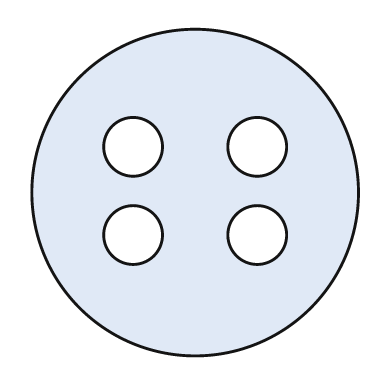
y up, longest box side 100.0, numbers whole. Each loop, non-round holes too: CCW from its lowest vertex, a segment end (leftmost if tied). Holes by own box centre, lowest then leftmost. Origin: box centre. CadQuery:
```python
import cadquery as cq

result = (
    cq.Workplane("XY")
    .moveTo(0.0, 0.0)
    .circle(50.0)
    .moveTo(-19.0, -13.0)
    .circle(9.0)
    .moveTo(19.0, -13.0)
    .circle(9.0)
    .moveTo(-19.0, 14.0)
    .circle(9.0)
    .moveTo(19.0, 14.0)
    .circle(9.0)
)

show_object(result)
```